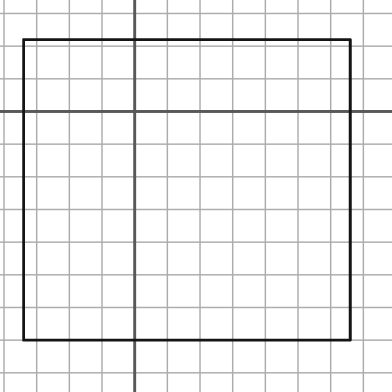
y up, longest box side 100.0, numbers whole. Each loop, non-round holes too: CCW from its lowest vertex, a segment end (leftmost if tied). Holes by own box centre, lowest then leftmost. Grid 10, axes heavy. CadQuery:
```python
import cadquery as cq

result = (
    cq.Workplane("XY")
    .moveTo(-34.0, -70.0)
    .lineTo(66.0, -70.0)
    .lineTo(66.0, 22.0)
    .lineTo(-34.0, 22.0)
    .close()
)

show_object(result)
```